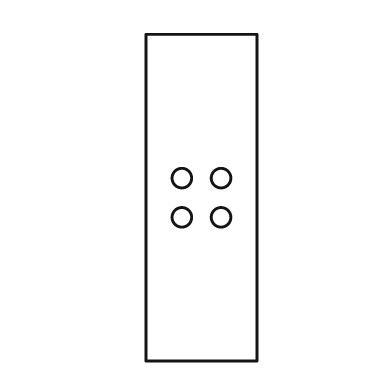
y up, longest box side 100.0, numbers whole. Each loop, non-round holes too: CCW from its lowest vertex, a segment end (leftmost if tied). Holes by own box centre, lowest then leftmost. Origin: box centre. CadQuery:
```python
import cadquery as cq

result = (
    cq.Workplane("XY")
    .moveTo(-17.0, -50.0)
    .lineTo(17.0, -50.0)
    .lineTo(17.0, 50.0)
    .lineTo(-17.0, 50.0)
    .close()
    .moveTo(-6.0, -6.0)
    .circle(3.0)
    .moveTo(6.0, -6.0)
    .circle(3.0)
    .moveTo(-6.0, 6.0)
    .circle(3.0)
    .moveTo(6.0, 6.0)
    .circle(3.0)
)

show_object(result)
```